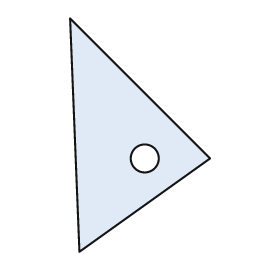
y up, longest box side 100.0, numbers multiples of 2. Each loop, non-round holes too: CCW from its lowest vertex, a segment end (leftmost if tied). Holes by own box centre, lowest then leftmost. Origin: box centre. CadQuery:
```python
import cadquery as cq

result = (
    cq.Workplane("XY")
    .moveTo(-26.0, -50.0)
    .lineTo(30.0, -10.0)
    .lineTo(-30.0, 50.0)
    .close()
    .moveTo(2.0, -10.0)
    .circle(6.0)
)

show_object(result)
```